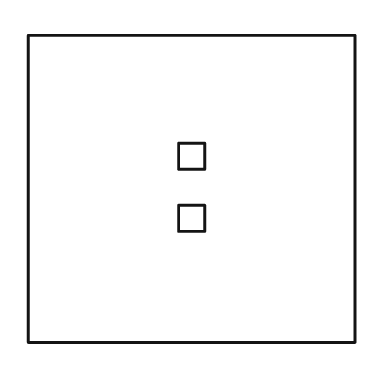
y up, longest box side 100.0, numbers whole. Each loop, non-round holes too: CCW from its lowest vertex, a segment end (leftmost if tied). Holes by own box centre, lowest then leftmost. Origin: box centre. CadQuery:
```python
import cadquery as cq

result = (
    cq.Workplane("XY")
    .moveTo(-50.0, -47.0)
    .lineTo(50.0, -47.0)
    .lineTo(50.0, 47.0)
    .lineTo(-50.0, 47.0)
    .close()
    .moveTo(-4.0, -13.0)
    .lineTo(4.0, -13.0)
    .lineTo(4.0, -5.0)
    .lineTo(-4.0, -5.0)
    .close()
    .moveTo(-4.0, 6.0)
    .lineTo(4.0, 6.0)
    .lineTo(4.0, 14.0)
    .lineTo(-4.0, 14.0)
    .close()
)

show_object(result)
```